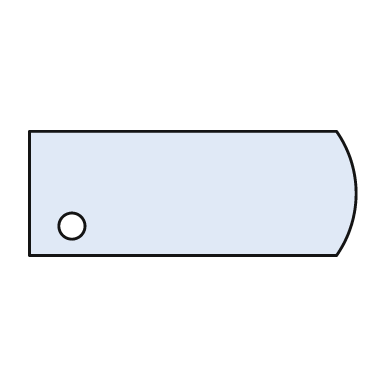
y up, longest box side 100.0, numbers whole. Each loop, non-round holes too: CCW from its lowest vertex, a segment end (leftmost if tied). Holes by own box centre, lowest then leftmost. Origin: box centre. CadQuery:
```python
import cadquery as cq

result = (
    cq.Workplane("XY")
    .moveTo(-50.0, -19.0)
    .lineTo(44.0, -19.0)
    .threePointArc((50.0, 0.0), (44.0, 19.0))
    .lineTo(-50.0, 19.0)
    .close()
    .moveTo(-37.0, -10.0)
    .circle(4.0)
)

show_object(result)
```